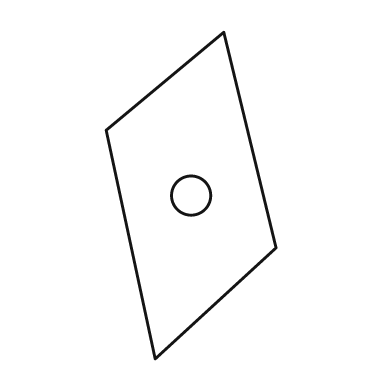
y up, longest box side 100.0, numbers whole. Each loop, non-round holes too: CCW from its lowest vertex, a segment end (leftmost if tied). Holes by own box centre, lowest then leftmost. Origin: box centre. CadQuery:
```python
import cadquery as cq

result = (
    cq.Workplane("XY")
    .moveTo(-11.0, -50.0)
    .lineTo(26.0, -16.0)
    .lineTo(10.0, 50.0)
    .lineTo(-26.0, 20.0)
    .close()
    .moveTo(0.0, 0.0)
    .circle(6.0)
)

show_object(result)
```